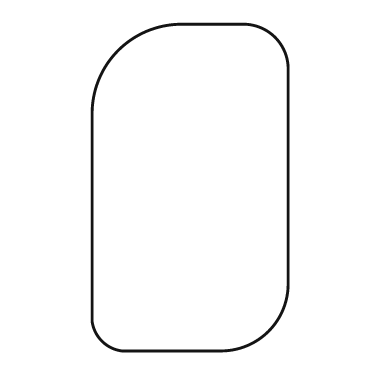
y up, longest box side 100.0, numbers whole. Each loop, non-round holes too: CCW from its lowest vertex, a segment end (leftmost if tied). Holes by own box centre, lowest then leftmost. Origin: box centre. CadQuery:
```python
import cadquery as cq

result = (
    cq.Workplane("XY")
    .moveTo(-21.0, -50.0)
    .lineTo(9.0, -50.0)
    .threePointArc((24.0, -44.0), (30.0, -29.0))
    .lineTo(30.0, 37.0)
    .threePointArc((26.0, 46.0), (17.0, 50.0))
    .lineTo(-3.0, 50.0)
    .threePointArc((-22.0, 42.0), (-30.0, 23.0))
    .lineTo(-30.0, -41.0)
    .threePointArc((-27.0, -47.0), (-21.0, -50.0))
    .close()
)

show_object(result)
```